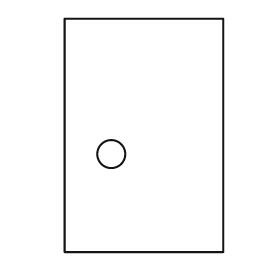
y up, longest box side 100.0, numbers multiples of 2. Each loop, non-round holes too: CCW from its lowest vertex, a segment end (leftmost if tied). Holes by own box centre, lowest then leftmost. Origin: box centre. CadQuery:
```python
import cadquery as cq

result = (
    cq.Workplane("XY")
    .moveTo(-34.0, -50.0)
    .lineTo(34.0, -50.0)
    .lineTo(34.0, 50.0)
    .lineTo(-34.0, 50.0)
    .close()
    .moveTo(-14.0, -8.0)
    .circle(6.0)
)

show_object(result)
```